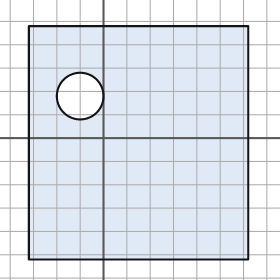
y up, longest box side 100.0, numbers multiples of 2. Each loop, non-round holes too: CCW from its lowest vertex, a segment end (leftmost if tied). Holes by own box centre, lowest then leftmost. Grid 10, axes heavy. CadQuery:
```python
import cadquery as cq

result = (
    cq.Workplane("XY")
    .moveTo(-32.0, -52.0)
    .lineTo(62.0, -52.0)
    .lineTo(62.0, 48.0)
    .lineTo(-32.0, 48.0)
    .close()
    .moveTo(-10.0, 18.0)
    .circle(10.0)
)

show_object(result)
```